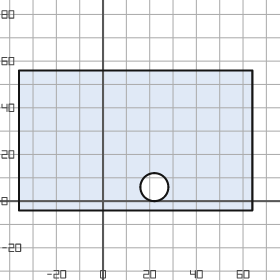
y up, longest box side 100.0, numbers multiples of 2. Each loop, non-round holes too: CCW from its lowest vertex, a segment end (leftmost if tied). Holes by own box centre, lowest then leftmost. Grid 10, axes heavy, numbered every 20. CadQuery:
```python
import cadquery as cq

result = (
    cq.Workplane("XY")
    .moveTo(-36.0, -4.0)
    .lineTo(64.0, -4.0)
    .lineTo(64.0, 56.0)
    .lineTo(-36.0, 56.0)
    .close()
    .moveTo(22.0, 6.0)
    .circle(6.0)
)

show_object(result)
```